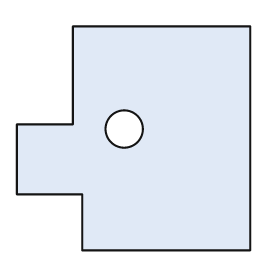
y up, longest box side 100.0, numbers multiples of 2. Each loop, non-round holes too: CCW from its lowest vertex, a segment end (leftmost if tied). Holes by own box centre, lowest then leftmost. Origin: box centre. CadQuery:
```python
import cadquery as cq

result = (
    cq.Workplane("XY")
    .moveTo(-22.0, -48.0)
    .lineTo(50.0, -48.0)
    .lineTo(50.0, 48.0)
    .lineTo(-26.0, 48.0)
    .lineTo(-26.0, 6.0)
    .lineTo(-50.0, 6.0)
    .lineTo(-50.0, -24.0)
    .lineTo(-22.0, -24.0)
    .close()
    .moveTo(-4.0, 4.0)
    .circle(8.0)
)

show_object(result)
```